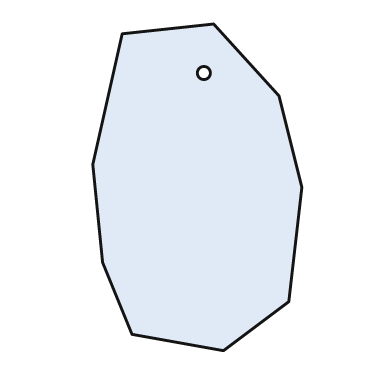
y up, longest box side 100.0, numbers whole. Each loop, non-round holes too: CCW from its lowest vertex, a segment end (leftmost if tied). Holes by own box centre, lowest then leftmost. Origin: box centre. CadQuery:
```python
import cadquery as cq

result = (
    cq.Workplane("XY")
    .moveTo(8.0, -50.0)
    .lineTo(28.0, -35.0)
    .lineTo(32.0, 0.0)
    .lineTo(25.0, 28.0)
    .lineTo(5.0, 50.0)
    .lineTo(-23.0, 47.0)
    .lineTo(-32.0, 7.0)
    .lineTo(-29.0, -23.0)
    .lineTo(-20.0, -45.0)
    .close()
    .moveTo(2.0, 35.0)
    .circle(2.0)
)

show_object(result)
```